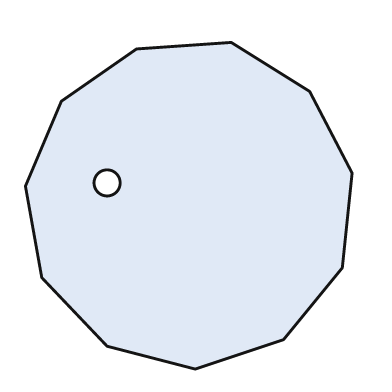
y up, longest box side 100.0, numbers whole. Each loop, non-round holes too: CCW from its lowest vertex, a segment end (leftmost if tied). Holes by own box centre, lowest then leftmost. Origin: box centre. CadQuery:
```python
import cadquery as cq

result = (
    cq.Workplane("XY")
    .moveTo(2.0, -50.0)
    .lineTo(29.0, -41.0)
    .lineTo(47.0, -19.0)
    .lineTo(50.0, 10.0)
    .lineTo(37.0, 35.0)
    .lineTo(13.0, 50.0)
    .lineTo(-16.0, 48.0)
    .lineTo(-39.0, 32.0)
    .lineTo(-50.0, 6.0)
    .lineTo(-45.0, -22.0)
    .lineTo(-25.0, -43.0)
    .close()
    .moveTo(-25.0, 7.0)
    .circle(4.0)
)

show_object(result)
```